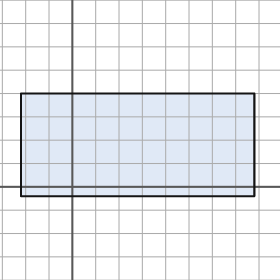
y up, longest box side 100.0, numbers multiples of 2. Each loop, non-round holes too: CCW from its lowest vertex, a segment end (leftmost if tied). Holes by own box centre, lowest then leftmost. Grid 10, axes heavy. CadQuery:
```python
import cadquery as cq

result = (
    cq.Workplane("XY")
    .moveTo(-22.0, -4.0)
    .lineTo(78.0, -4.0)
    .lineTo(78.0, 40.0)
    .lineTo(-22.0, 40.0)
    .close()
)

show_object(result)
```